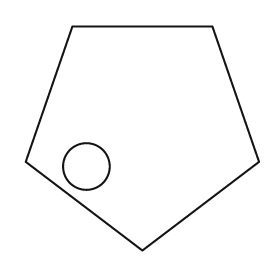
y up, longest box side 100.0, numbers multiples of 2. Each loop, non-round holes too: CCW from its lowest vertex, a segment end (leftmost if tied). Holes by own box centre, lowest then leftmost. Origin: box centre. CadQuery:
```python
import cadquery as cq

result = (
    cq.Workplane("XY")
    .moveTo(0.0, -48.0)
    .lineTo(50.0, -10.0)
    .lineTo(30.0, 48.0)
    .lineTo(-30.0, 48.0)
    .lineTo(-50.0, -10.0)
    .close()
    .moveTo(-24.0, -12.0)
    .circle(10.0)
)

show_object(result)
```